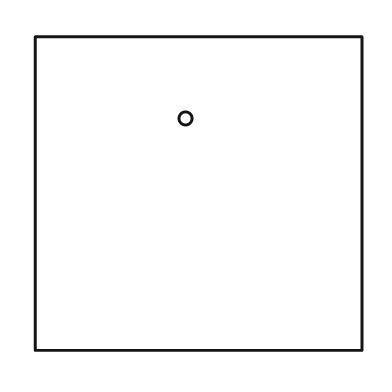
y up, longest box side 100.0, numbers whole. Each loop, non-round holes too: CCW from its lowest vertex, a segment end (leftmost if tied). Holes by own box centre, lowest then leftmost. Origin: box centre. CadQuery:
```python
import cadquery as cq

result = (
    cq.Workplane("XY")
    .moveTo(-50.0, -48.0)
    .lineTo(50.0, -48.0)
    .lineTo(50.0, 48.0)
    .lineTo(-50.0, 48.0)
    .close()
    .moveTo(-4.0, 23.0)
    .circle(2.0)
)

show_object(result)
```